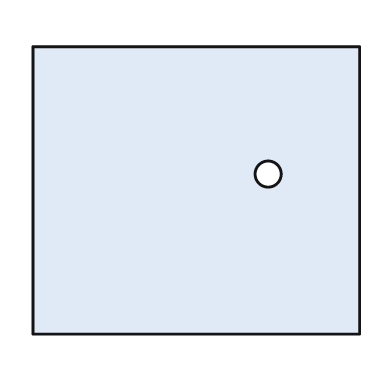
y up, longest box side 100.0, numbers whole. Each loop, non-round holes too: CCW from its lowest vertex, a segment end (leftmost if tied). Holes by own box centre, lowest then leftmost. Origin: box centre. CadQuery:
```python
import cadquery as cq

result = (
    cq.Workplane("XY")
    .moveTo(-50.0, -44.0)
    .lineTo(50.0, -44.0)
    .lineTo(50.0, 44.0)
    .lineTo(-50.0, 44.0)
    .close()
    .moveTo(22.0, 5.0)
    .circle(4.0)
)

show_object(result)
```